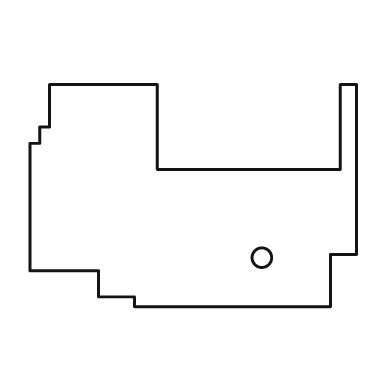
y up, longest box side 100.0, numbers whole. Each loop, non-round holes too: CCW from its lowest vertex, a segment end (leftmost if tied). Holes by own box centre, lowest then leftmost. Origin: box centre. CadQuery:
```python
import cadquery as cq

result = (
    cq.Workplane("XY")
    .moveTo(-18.0, -34.0)
    .lineTo(42.0, -34.0)
    .lineTo(42.0, -18.0)
    .lineTo(50.0, -18.0)
    .lineTo(50.0, 34.0)
    .lineTo(45.0, 34.0)
    .lineTo(45.0, 8.0)
    .lineTo(-11.0, 8.0)
    .lineTo(-11.0, 34.0)
    .lineTo(-44.0, 34.0)
    .lineTo(-44.0, 21.0)
    .lineTo(-47.0, 21.0)
    .lineTo(-47.0, 16.0)
    .lineTo(-50.0, 16.0)
    .lineTo(-50.0, -23.0)
    .lineTo(-29.0, -23.0)
    .lineTo(-29.0, -31.0)
    .lineTo(-18.0, -31.0)
    .close()
    .moveTo(21.0, -19.0)
    .circle(3.0)
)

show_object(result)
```